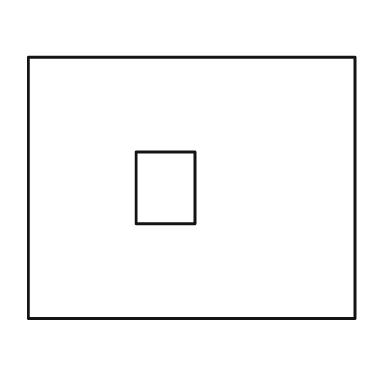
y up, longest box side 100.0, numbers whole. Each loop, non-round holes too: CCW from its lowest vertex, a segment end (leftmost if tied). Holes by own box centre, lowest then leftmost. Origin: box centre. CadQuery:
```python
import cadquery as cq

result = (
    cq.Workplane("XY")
    .moveTo(-50.0, -40.0)
    .lineTo(50.0, -40.0)
    .lineTo(50.0, 40.0)
    .lineTo(-50.0, 40.0)
    .close()
    .moveTo(-17.0, -11.0)
    .lineTo(1.0, -11.0)
    .lineTo(1.0, 11.0)
    .lineTo(-17.0, 11.0)
    .close()
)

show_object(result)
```